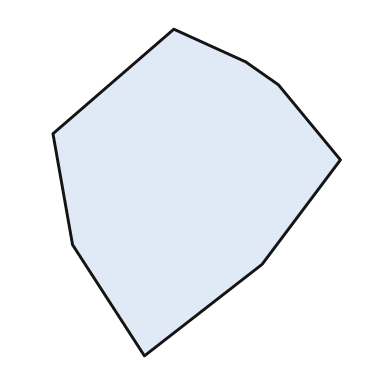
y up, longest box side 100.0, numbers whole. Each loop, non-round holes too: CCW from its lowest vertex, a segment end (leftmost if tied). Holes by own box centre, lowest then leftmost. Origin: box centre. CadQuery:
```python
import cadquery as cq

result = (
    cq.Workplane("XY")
    .moveTo(-16.0, -50.0)
    .lineTo(20.0, -22.0)
    .lineTo(44.0, 10.0)
    .lineTo(25.0, 33.0)
    .lineTo(15.0, 40.0)
    .lineTo(-7.0, 50.0)
    .lineTo(-44.0, 18.0)
    .lineTo(-38.0, -16.0)
    .close()
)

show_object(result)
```